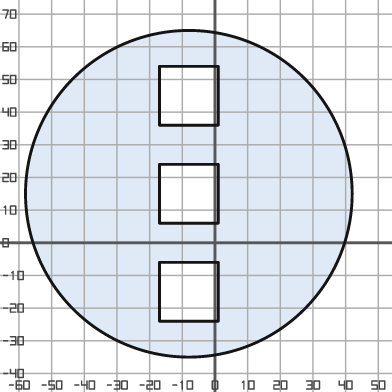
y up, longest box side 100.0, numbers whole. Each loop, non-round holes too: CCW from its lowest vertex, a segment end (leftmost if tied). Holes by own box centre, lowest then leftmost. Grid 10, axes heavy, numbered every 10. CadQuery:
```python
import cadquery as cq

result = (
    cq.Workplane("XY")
    .moveTo(-8.0, 15.0)
    .circle(50.0)
    .moveTo(-17.0, -24.0)
    .lineTo(1.0, -24.0)
    .lineTo(1.0, -6.0)
    .lineTo(-17.0, -6.0)
    .close()
    .moveTo(-17.0, 6.0)
    .lineTo(1.0, 6.0)
    .lineTo(1.0, 24.0)
    .lineTo(-17.0, 24.0)
    .close()
    .moveTo(-17.0, 36.0)
    .lineTo(1.0, 36.0)
    .lineTo(1.0, 54.0)
    .lineTo(-17.0, 54.0)
    .close()
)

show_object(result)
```